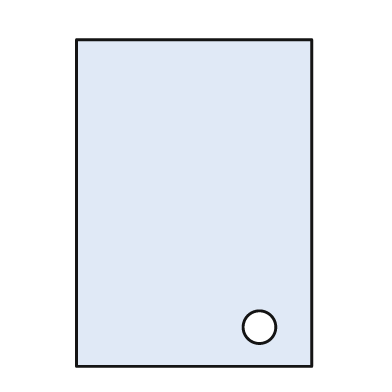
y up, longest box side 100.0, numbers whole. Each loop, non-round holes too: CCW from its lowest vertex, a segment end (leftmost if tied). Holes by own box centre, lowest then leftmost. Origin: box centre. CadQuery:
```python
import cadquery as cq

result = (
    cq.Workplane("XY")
    .moveTo(-36.0, -50.0)
    .lineTo(36.0, -50.0)
    .lineTo(36.0, 50.0)
    .lineTo(-36.0, 50.0)
    .close()
    .moveTo(20.0, -38.0)
    .circle(5.0)
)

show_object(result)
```